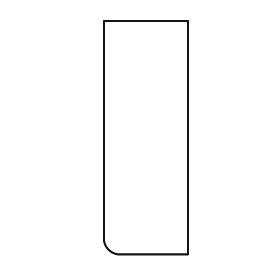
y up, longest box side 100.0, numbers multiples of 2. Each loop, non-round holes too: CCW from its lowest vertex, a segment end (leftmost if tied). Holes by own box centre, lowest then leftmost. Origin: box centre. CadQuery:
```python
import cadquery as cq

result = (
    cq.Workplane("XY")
    .moveTo(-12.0, -50.0)
    .lineTo(18.0, -50.0)
    .lineTo(18.0, 50.0)
    .lineTo(-18.0, 50.0)
    .lineTo(-18.0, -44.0)
    .threePointArc((-16.0, -48.0), (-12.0, -50.0))
    .close()
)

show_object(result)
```